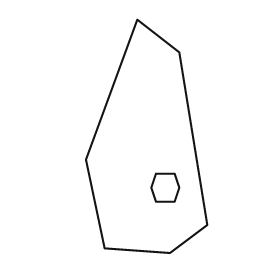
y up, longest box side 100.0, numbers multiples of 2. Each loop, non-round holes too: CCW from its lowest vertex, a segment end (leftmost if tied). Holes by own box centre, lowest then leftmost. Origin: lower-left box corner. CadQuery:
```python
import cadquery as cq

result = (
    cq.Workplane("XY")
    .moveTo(36.0, 0.0)
    .lineTo(52.0, 12.0)
    .lineTo(40.0, 86.0)
    .lineTo(22.0, 100.0)
    .lineTo(0.0, 40.0)
    .lineTo(8.0, 2.0)
    .close()
    .moveTo(30.0, 22.0)
    .lineTo(38.0, 22.0)
    .lineTo(40.0, 28.0)
    .lineTo(38.0, 34.0)
    .lineTo(30.0, 34.0)
    .lineTo(28.0, 28.0)
    .close()
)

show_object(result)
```